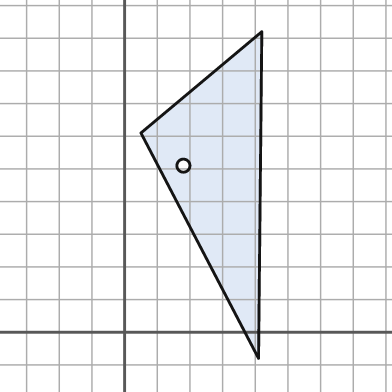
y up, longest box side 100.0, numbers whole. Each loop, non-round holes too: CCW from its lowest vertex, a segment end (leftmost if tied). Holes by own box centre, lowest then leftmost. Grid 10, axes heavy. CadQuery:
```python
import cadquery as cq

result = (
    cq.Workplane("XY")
    .moveTo(41.0, -8.0)
    .lineTo(42.0, 92.0)
    .lineTo(5.0, 61.0)
    .close()
    .moveTo(18.0, 51.0)
    .circle(2.0)
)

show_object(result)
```